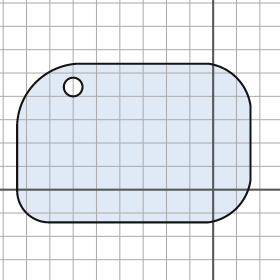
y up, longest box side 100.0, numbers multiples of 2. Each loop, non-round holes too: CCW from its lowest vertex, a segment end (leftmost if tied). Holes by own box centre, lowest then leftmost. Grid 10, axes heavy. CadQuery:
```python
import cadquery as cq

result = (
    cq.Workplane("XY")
    .moveTo(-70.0, -14.0)
    .lineTo(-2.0, -14.0)
    .threePointArc((10.0, -8.0), (16.0, 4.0))
    .lineTo(16.0, 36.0)
    .threePointArc((10.0, 48.0), (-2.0, 54.0))
    .lineTo(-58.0, 54.0)
    .threePointArc((-76.0, 46.0), (-84.0, 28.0))
    .lineTo(-84.0, 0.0)
    .threePointArc((-80.0, -10.0), (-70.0, -14.0))
    .close()
    .moveTo(-60.0, 44.0)
    .circle(4.0)
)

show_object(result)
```